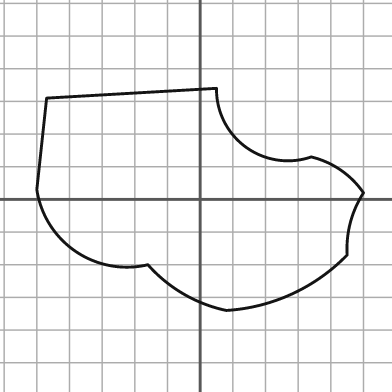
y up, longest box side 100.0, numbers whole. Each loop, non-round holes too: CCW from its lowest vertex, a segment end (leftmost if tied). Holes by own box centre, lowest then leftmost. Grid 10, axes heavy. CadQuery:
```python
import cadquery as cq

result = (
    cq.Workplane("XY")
    .moveTo(8.0, -34.0)
    .threePointArc((28.0, -29.0), (45.0, -17.0))
    .threePointArc((46.0, -7.0), (50.0, 2.0))
    .threePointArc((43.0, 9.0), (34.0, 13.0))
    .threePointArc((14.0, 16.0), (5.0, 34.0))
    .lineTo(-47.0, 31.0)
    .lineTo(-50.0, 3.0)
    .threePointArc((-38.0, -16.0), (-16.0, -20.0))
    .threePointArc((-5.0, -29.0), (8.0, -34.0))
    .close()
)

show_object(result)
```